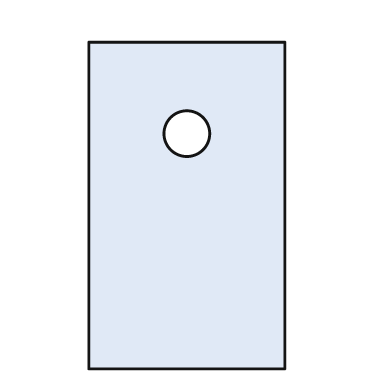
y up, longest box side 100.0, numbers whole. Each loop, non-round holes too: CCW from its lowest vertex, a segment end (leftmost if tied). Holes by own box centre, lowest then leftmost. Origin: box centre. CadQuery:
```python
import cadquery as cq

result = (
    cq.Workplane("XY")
    .moveTo(-30.0, -50.0)
    .lineTo(30.0, -50.0)
    .lineTo(30.0, 50.0)
    .lineTo(-30.0, 50.0)
    .close()
    .moveTo(0.0, 22.0)
    .circle(7.0)
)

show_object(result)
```